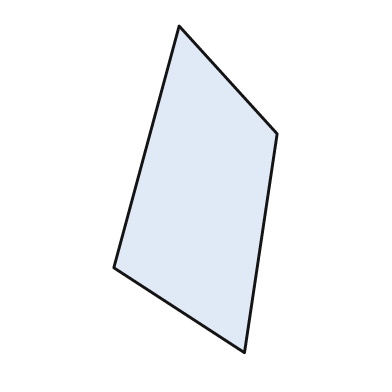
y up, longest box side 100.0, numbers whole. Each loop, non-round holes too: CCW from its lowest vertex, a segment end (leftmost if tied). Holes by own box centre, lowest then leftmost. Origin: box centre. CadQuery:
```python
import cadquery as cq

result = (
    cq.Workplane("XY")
    .moveTo(15.0, -50.0)
    .lineTo(25.0, 17.0)
    .lineTo(-5.0, 50.0)
    .lineTo(-25.0, -24.0)
    .close()
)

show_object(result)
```